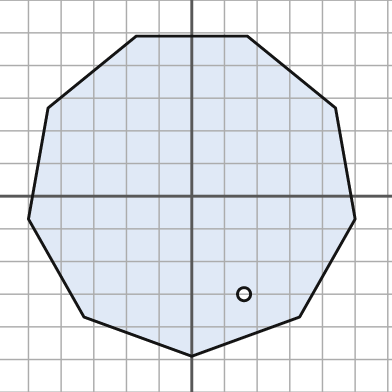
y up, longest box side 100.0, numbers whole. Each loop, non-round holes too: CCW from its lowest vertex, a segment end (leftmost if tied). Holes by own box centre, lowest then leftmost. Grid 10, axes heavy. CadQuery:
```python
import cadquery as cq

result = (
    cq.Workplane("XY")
    .moveTo(0.0, -49.0)
    .lineTo(33.0, -37.0)
    .lineTo(50.0, -7.0)
    .lineTo(44.0, 27.0)
    .lineTo(17.0, 49.0)
    .lineTo(-17.0, 49.0)
    .lineTo(-44.0, 27.0)
    .lineTo(-50.0, -7.0)
    .lineTo(-33.0, -37.0)
    .close()
    .moveTo(16.0, -30.0)
    .circle(2.0)
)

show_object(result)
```